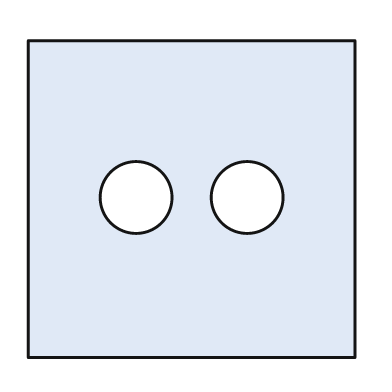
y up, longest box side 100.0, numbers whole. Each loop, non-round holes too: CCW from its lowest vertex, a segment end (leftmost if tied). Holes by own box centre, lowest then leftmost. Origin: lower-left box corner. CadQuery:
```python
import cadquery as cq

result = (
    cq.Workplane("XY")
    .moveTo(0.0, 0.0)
    .lineTo(100.0, 0.0)
    .lineTo(100.0, 97.0)
    .lineTo(0.0, 97.0)
    .close()
    .moveTo(33.0, 49.0)
    .circle(11.0)
    .moveTo(67.0, 49.0)
    .circle(11.0)
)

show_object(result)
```